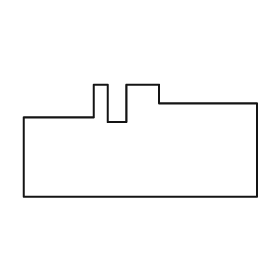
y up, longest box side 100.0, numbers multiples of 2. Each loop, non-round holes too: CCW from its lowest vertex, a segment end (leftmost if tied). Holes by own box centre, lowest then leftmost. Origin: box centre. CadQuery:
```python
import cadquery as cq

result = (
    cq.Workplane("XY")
    .moveTo(-50.0, -24.0)
    .lineTo(50.0, -24.0)
    .lineTo(50.0, 16.0)
    .lineTo(8.0, 16.0)
    .lineTo(8.0, 24.0)
    .lineTo(-6.0, 24.0)
    .lineTo(-6.0, 8.0)
    .lineTo(-14.0, 8.0)
    .lineTo(-14.0, 24.0)
    .lineTo(-20.0, 24.0)
    .lineTo(-20.0, 10.0)
    .lineTo(-50.0, 10.0)
    .close()
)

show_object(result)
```